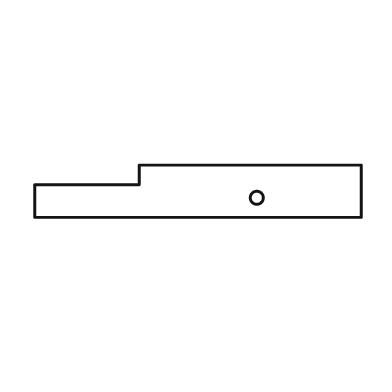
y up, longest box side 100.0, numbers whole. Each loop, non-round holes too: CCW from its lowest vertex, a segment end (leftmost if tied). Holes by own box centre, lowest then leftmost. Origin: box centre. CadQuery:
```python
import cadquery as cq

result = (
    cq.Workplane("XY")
    .moveTo(-50.0, -8.0)
    .lineTo(50.0, -8.0)
    .lineTo(50.0, 8.0)
    .lineTo(-18.0, 8.0)
    .lineTo(-18.0, 2.0)
    .lineTo(-50.0, 2.0)
    .close()
    .moveTo(18.0, -2.0)
    .circle(2.0)
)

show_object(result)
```